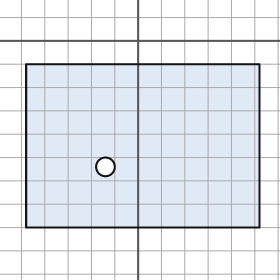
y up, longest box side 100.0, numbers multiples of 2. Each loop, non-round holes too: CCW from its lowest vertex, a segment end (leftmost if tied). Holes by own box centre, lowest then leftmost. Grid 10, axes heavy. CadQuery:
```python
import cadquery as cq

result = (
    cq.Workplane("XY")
    .moveTo(-48.0, -80.0)
    .lineTo(52.0, -80.0)
    .lineTo(52.0, -10.0)
    .lineTo(-48.0, -10.0)
    .close()
    .moveTo(-14.0, -54.0)
    .circle(4.0)
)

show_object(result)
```